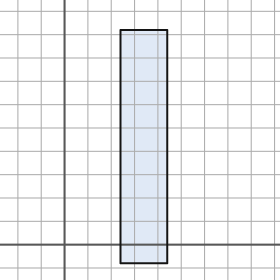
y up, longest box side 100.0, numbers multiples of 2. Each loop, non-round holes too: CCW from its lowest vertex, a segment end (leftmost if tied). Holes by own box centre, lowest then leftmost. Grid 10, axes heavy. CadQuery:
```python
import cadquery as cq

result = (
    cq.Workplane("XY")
    .moveTo(24.0, -8.0)
    .lineTo(44.0, -8.0)
    .lineTo(44.0, 92.0)
    .lineTo(24.0, 92.0)
    .close()
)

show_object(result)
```